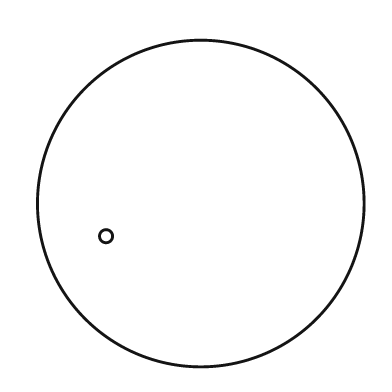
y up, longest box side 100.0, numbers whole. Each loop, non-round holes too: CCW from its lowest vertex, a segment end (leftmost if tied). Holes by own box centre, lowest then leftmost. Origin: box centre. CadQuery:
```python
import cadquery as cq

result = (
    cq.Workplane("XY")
    .moveTo(0.0, 0.0)
    .circle(50.0)
    .moveTo(-29.0, -10.0)
    .circle(2.0)
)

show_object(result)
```